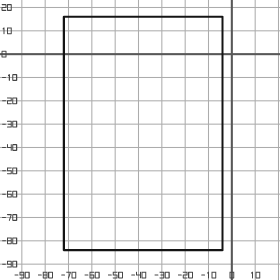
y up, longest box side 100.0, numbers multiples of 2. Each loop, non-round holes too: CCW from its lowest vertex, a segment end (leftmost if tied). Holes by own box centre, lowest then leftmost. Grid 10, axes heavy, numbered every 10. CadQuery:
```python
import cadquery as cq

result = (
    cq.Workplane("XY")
    .moveTo(-72.0, -84.0)
    .lineTo(-4.0, -84.0)
    .lineTo(-4.0, 16.0)
    .lineTo(-72.0, 16.0)
    .close()
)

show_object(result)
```